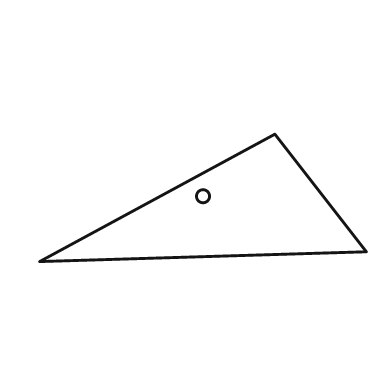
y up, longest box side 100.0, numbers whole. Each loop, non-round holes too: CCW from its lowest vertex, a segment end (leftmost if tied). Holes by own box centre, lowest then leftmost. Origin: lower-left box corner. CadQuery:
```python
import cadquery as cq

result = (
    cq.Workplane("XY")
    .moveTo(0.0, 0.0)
    .lineTo(100.0, 3.0)
    .lineTo(72.0, 39.0)
    .close()
    .moveTo(50.0, 20.0)
    .circle(2.0)
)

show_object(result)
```